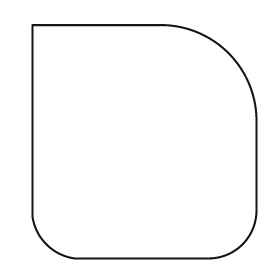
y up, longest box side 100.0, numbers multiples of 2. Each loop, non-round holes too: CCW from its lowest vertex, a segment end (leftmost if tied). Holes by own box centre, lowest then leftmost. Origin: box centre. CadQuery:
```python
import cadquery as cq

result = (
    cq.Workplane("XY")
    .moveTo(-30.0, -50.0)
    .lineTo(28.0, -50.0)
    .threePointArc((42.0, -44.0), (48.0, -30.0))
    .lineTo(48.0, 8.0)
    .threePointArc((36.0, 38.0), (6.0, 50.0))
    .lineTo(-48.0, 50.0)
    .lineTo(-48.0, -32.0)
    .threePointArc((-42.0, -44.0), (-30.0, -50.0))
    .close()
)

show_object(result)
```